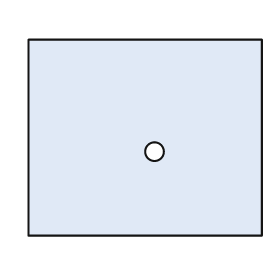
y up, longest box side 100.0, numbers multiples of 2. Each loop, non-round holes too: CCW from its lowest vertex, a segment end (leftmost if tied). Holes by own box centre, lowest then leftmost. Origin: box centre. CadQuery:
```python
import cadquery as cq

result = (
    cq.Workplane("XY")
    .moveTo(-50.0, -42.0)
    .lineTo(50.0, -42.0)
    .lineTo(50.0, 42.0)
    .lineTo(-50.0, 42.0)
    .close()
    .moveTo(4.0, -6.0)
    .circle(4.0)
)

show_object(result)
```